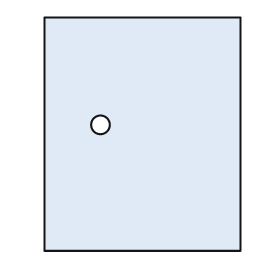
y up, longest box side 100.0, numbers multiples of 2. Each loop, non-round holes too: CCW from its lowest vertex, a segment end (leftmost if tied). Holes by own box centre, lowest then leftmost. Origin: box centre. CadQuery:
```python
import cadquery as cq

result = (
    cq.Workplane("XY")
    .moveTo(-42.0, -50.0)
    .lineTo(42.0, -50.0)
    .lineTo(42.0, 50.0)
    .lineTo(-42.0, 50.0)
    .close()
    .moveTo(-18.0, 4.0)
    .circle(4.0)
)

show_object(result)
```